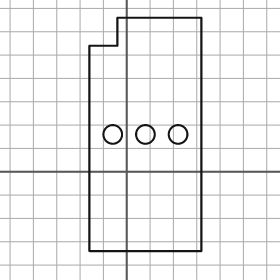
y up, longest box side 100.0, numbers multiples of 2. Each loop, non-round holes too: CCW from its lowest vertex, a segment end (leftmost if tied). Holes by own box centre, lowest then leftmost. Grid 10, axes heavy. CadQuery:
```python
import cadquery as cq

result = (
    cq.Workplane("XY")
    .moveTo(-16.0, -34.0)
    .lineTo(32.0, -34.0)
    .lineTo(32.0, 66.0)
    .lineTo(-4.0, 66.0)
    .lineTo(-4.0, 54.0)
    .lineTo(-16.0, 54.0)
    .close()
    .moveTo(-6.0, 16.0)
    .circle(4.0)
    .moveTo(8.0, 16.0)
    .circle(4.0)
    .moveTo(22.0, 16.0)
    .circle(4.0)
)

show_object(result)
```